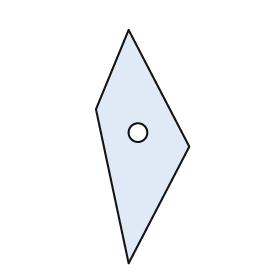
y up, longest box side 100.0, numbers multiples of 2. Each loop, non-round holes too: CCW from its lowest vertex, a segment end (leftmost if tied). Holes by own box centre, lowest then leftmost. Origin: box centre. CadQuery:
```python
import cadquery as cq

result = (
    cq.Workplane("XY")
    .moveTo(-6.0, -50.0)
    .lineTo(20.0, 0.0)
    .lineTo(-6.0, 50.0)
    .lineTo(-20.0, 16.0)
    .close()
    .moveTo(-2.0, 6.0)
    .circle(4.0)
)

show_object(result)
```